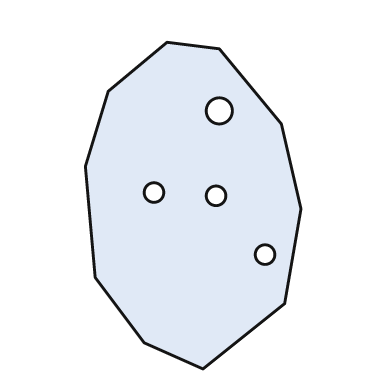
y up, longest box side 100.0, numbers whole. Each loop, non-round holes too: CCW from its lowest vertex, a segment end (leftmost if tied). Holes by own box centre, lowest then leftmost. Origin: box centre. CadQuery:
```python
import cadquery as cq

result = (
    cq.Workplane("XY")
    .moveTo(3.0, -50.0)
    .lineTo(28.0, -30.0)
    .lineTo(33.0, -1.0)
    .lineTo(27.0, 25.0)
    .lineTo(8.0, 48.0)
    .lineTo(-8.0, 50.0)
    .lineTo(-26.0, 35.0)
    .lineTo(-33.0, 12.0)
    .lineTo(-30.0, -22.0)
    .lineTo(-15.0, -42.0)
    .close()
    .moveTo(22.0, -15.0)
    .circle(3.0)
    .moveTo(7.0, 3.0)
    .circle(3.0)
    .moveTo(-12.0, 4.0)
    .circle(3.0)
    .moveTo(8.0, 29.0)
    .circle(4.0)
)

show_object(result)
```